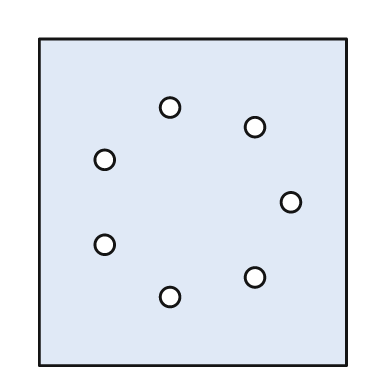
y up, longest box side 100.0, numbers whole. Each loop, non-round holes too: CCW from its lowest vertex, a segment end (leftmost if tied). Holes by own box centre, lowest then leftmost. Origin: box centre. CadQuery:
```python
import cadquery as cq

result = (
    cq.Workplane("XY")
    .moveTo(-47.0, -50.0)
    .lineTo(47.0, -50.0)
    .lineTo(47.0, 50.0)
    .lineTo(-47.0, 50.0)
    .close()
    .moveTo(-7.0, -29.0)
    .circle(3.0)
    .moveTo(19.0, -23.0)
    .circle(3.0)
    .moveTo(-27.0, -13.0)
    .circle(3.0)
    .moveTo(30.0, 0.0)
    .circle(3.0)
    .moveTo(-27.0, 13.0)
    .circle(3.0)
    .moveTo(19.0, 23.0)
    .circle(3.0)
    .moveTo(-7.0, 29.0)
    .circle(3.0)
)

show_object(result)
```